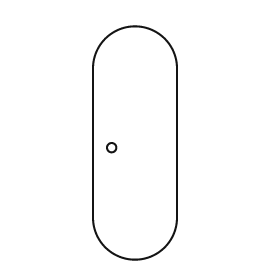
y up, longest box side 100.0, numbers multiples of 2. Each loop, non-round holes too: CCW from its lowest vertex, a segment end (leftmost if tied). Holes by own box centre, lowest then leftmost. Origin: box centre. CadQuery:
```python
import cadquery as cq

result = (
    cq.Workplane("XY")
    .moveTo(-18.0, -32.0)
    .threePointArc((0.0, -50.0), (18.0, -32.0))
    .lineTo(18.0, 32.0)
    .threePointArc((0.0, 50.0), (-18.0, 32.0))
    .close()
    .moveTo(-10.0, -2.0)
    .circle(2.0)
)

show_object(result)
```